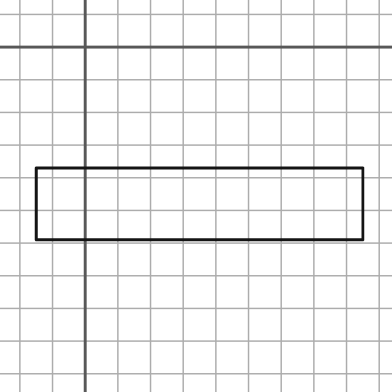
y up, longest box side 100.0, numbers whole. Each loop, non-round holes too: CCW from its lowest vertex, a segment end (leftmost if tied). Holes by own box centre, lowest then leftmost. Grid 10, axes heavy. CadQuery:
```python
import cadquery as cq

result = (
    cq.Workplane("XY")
    .moveTo(-15.0, -59.0)
    .lineTo(85.0, -59.0)
    .lineTo(85.0, -37.0)
    .lineTo(-15.0, -37.0)
    .close()
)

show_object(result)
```